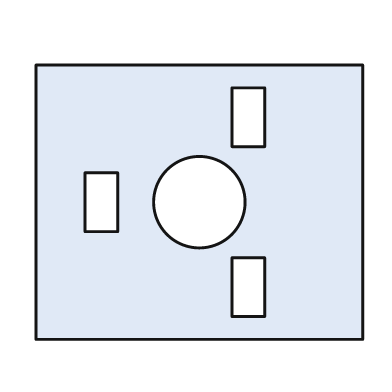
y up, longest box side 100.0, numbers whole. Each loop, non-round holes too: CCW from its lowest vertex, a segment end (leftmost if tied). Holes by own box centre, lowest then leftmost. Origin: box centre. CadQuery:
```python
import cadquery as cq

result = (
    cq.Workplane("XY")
    .moveTo(-50.0, -42.0)
    .lineTo(50.0, -42.0)
    .lineTo(50.0, 42.0)
    .lineTo(-50.0, 42.0)
    .close()
    .moveTo(10.0, -35.0)
    .lineTo(20.0, -35.0)
    .lineTo(20.0, -17.0)
    .lineTo(10.0, -17.0)
    .close()
    .moveTo(-35.0, -9.0)
    .lineTo(-25.0, -9.0)
    .lineTo(-25.0, 9.0)
    .lineTo(-35.0, 9.0)
    .close()
    .moveTo(0.0, 0.0)
    .circle(14.0)
    .moveTo(10.0, 17.0)
    .lineTo(20.0, 17.0)
    .lineTo(20.0, 35.0)
    .lineTo(10.0, 35.0)
    .close()
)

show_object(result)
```